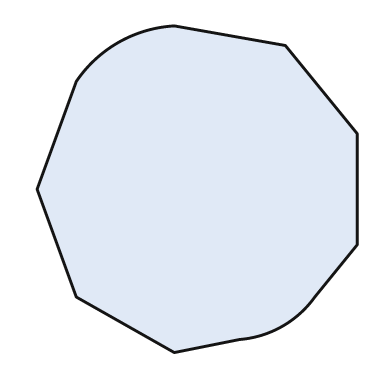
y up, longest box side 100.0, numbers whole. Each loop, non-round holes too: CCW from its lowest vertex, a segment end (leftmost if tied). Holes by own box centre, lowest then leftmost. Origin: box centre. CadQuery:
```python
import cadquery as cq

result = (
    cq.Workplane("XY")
    .moveTo(-7.0, -50.0)
    .lineTo(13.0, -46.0)
    .threePointArc((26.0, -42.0), (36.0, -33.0))
    .lineTo(49.0, -17.0)
    .lineTo(49.0, 17.0)
    .lineTo(27.0, 44.0)
    .lineTo(-7.0, 50.0)
    .threePointArc((-24.0, 45.0), (-37.0, 33.0))
    .lineTo(-49.0, 0.0)
    .lineTo(-37.0, -33.0)
    .close()
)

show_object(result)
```